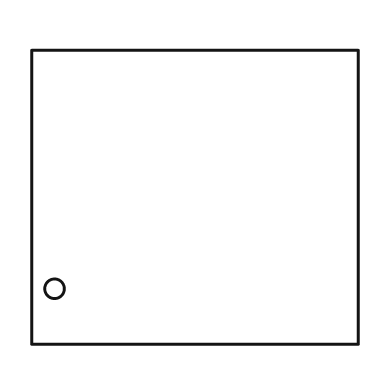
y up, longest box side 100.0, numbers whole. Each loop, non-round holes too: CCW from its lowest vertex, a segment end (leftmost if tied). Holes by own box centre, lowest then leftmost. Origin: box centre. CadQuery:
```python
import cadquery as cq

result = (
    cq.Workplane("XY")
    .moveTo(-50.0, -45.0)
    .lineTo(50.0, -45.0)
    .lineTo(50.0, 45.0)
    .lineTo(-50.0, 45.0)
    .close()
    .moveTo(-43.0, -28.0)
    .circle(3.0)
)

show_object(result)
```